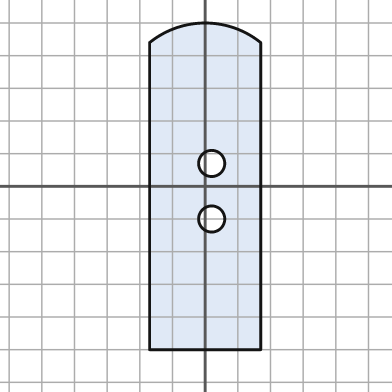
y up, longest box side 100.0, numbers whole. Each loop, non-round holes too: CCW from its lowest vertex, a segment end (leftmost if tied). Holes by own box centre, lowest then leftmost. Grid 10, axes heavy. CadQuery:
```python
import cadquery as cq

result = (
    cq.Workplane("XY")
    .moveTo(-17.0, -50.0)
    .lineTo(17.0, -50.0)
    .lineTo(17.0, 44.0)
    .threePointArc((0.0, 50.0), (-17.0, 44.0))
    .close()
    .moveTo(2.0, -10.0)
    .circle(4.0)
    .moveTo(2.0, 7.0)
    .circle(4.0)
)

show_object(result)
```